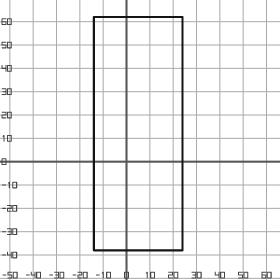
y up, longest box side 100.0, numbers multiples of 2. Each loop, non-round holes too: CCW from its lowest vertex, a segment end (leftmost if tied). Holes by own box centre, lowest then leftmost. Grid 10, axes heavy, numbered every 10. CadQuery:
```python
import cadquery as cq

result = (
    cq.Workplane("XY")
    .moveTo(-14.0, -38.0)
    .lineTo(24.0, -38.0)
    .lineTo(24.0, 62.0)
    .lineTo(-14.0, 62.0)
    .close()
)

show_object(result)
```